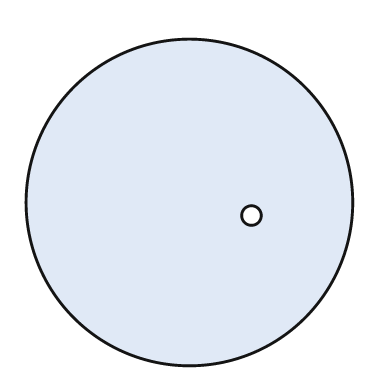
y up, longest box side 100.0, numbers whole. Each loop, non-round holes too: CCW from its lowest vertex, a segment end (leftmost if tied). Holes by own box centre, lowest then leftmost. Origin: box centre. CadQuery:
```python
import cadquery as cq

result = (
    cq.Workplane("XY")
    .moveTo(0.0, 0.0)
    .circle(50.0)
    .moveTo(19.0, -4.0)
    .circle(3.0)
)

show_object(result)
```